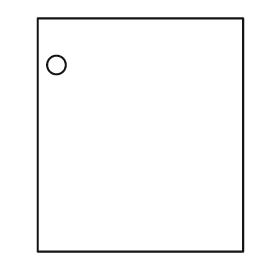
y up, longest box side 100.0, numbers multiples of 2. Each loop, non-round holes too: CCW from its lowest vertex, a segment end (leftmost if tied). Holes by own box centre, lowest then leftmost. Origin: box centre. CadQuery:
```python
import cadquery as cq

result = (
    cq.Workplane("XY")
    .moveTo(-44.0, -50.0)
    .lineTo(44.0, -50.0)
    .lineTo(44.0, 50.0)
    .lineTo(-44.0, 50.0)
    .close()
    .moveTo(-36.0, 30.0)
    .circle(4.0)
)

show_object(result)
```